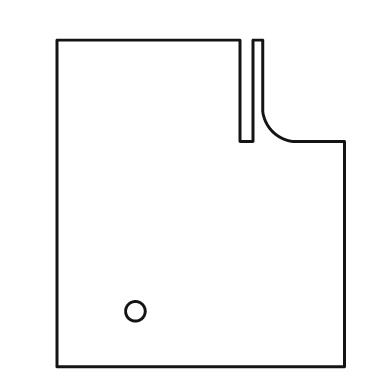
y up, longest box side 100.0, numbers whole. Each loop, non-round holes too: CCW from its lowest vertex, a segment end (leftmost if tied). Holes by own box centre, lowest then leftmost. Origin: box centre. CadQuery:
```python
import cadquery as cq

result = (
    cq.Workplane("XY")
    .moveTo(-44.0, -50.0)
    .lineTo(44.0, -50.0)
    .lineTo(44.0, 19.0)
    .lineTo(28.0, 19.0)
    .threePointArc((22.0, 22.0), (19.0, 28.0))
    .lineTo(19.0, 50.0)
    .lineTo(16.0, 50.0)
    .lineTo(16.0, 19.0)
    .lineTo(12.0, 19.0)
    .lineTo(12.0, 50.0)
    .lineTo(-44.0, 50.0)
    .close()
    .moveTo(-20.0, -33.0)
    .circle(3.0)
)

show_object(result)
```